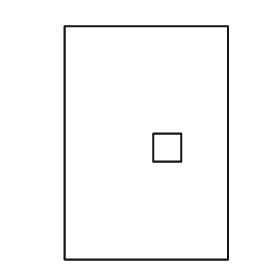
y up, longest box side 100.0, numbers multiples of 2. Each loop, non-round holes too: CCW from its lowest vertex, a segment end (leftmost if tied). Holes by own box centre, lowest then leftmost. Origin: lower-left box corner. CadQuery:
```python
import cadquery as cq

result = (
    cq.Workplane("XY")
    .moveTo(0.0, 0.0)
    .lineTo(70.0, 0.0)
    .lineTo(70.0, 100.0)
    .lineTo(0.0, 100.0)
    .close()
    .moveTo(38.0, 42.0)
    .lineTo(50.0, 42.0)
    .lineTo(50.0, 54.0)
    .lineTo(38.0, 54.0)
    .close()
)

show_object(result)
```